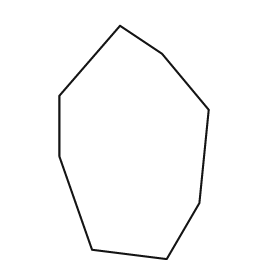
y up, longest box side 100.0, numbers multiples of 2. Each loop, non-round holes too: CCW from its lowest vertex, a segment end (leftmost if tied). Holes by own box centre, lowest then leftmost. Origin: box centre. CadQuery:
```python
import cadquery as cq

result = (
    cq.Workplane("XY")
    .moveTo(14.0, -50.0)
    .lineTo(28.0, -26.0)
    .lineTo(32.0, 14.0)
    .lineTo(12.0, 38.0)
    .lineTo(-6.0, 50.0)
    .lineTo(-32.0, 20.0)
    .lineTo(-32.0, -6.0)
    .lineTo(-18.0, -46.0)
    .close()
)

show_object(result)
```